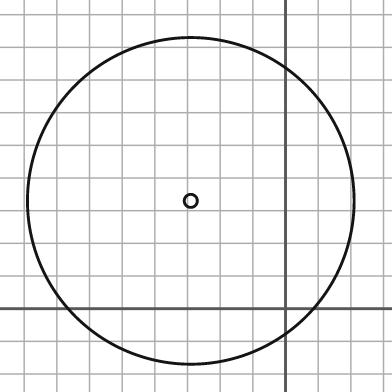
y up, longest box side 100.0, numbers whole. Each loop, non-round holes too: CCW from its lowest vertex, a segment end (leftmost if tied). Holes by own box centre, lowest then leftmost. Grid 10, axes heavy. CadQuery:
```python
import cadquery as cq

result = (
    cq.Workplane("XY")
    .moveTo(-29.0, 33.0)
    .circle(50.0)
    .moveTo(-29.0, 33.0)
    .circle(2.0)
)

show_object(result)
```